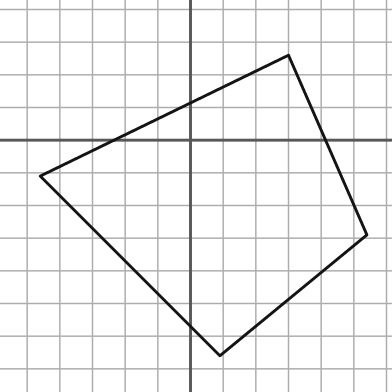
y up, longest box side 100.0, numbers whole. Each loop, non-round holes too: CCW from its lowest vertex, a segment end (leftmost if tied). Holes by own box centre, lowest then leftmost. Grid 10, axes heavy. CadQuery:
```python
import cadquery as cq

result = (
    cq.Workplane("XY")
    .moveTo(9.0, -66.0)
    .lineTo(54.0, -29.0)
    .lineTo(30.0, 26.0)
    .lineTo(-46.0, -11.0)
    .close()
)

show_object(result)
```